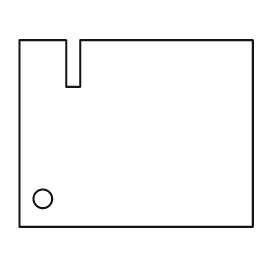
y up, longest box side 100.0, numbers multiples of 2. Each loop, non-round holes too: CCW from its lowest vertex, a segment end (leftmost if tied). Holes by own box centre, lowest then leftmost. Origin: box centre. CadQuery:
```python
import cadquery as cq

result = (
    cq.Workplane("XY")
    .moveTo(-50.0, -40.0)
    .lineTo(50.0, -40.0)
    .lineTo(50.0, 40.0)
    .lineTo(-24.0, 40.0)
    .lineTo(-24.0, 20.0)
    .lineTo(-30.0, 20.0)
    .lineTo(-30.0, 40.0)
    .lineTo(-50.0, 40.0)
    .close()
    .moveTo(-40.0, -28.0)
    .circle(4.0)
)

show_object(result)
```